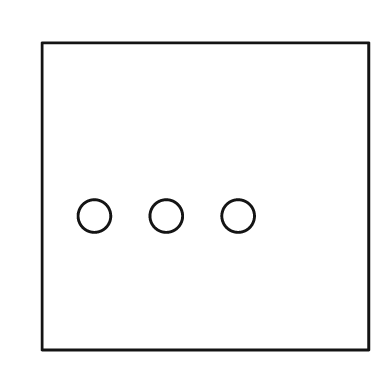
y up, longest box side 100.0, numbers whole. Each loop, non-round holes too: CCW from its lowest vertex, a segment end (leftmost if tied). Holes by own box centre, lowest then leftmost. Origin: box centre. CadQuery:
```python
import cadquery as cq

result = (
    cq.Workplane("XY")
    .moveTo(-50.0, -47.0)
    .lineTo(50.0, -47.0)
    .lineTo(50.0, 47.0)
    .lineTo(-50.0, 47.0)
    .close()
    .moveTo(-34.0, -6.0)
    .circle(5.0)
    .moveTo(-12.0, -6.0)
    .circle(5.0)
    .moveTo(10.0, -6.0)
    .circle(5.0)
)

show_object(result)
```